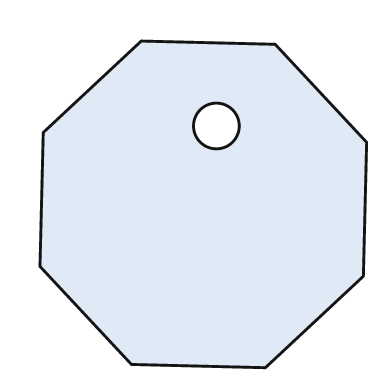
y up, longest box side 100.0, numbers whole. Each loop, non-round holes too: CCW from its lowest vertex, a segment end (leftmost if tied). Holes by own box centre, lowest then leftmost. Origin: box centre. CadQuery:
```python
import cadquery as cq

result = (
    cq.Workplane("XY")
    .moveTo(19.0, -50.0)
    .lineTo(49.0, -22.0)
    .lineTo(50.0, 19.0)
    .lineTo(22.0, 49.0)
    .lineTo(-19.0, 50.0)
    .lineTo(-49.0, 22.0)
    .lineTo(-50.0, -19.0)
    .lineTo(-22.0, -49.0)
    .close()
    .moveTo(4.0, 24.0)
    .circle(7.0)
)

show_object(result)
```